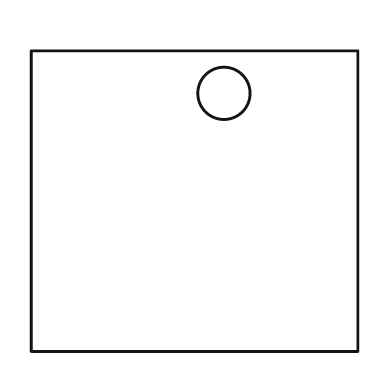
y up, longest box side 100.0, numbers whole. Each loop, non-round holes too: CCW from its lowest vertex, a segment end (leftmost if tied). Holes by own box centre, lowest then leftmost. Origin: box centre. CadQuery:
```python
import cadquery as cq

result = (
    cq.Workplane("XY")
    .moveTo(-50.0, -46.0)
    .lineTo(50.0, -46.0)
    .lineTo(50.0, 46.0)
    .lineTo(-50.0, 46.0)
    .close()
    .moveTo(9.0, 33.0)
    .circle(8.0)
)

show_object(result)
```